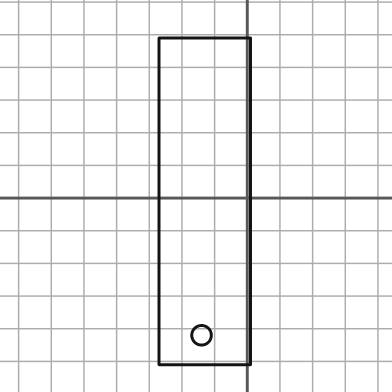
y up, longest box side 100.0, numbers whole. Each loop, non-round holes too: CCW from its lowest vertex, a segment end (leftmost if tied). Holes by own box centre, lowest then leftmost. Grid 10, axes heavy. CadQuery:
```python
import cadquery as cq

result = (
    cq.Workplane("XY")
    .moveTo(-27.0, -51.0)
    .lineTo(1.0, -51.0)
    .lineTo(1.0, 49.0)
    .lineTo(-27.0, 49.0)
    .close()
    .moveTo(-14.0, -42.0)
    .circle(3.0)
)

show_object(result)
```